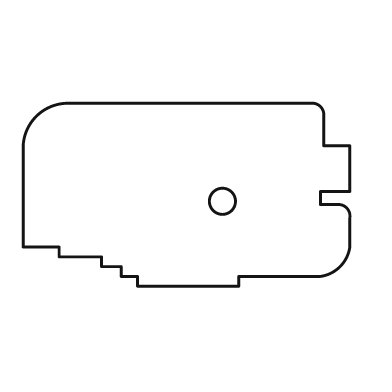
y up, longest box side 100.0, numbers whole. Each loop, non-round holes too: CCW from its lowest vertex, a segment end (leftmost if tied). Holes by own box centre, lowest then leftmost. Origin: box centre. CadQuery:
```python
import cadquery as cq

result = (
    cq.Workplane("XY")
    .moveTo(-15.0, -28.0)
    .lineTo(16.0, -28.0)
    .lineTo(16.0, -25.0)
    .lineTo(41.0, -25.0)
    .threePointArc((47.0, -22.0), (50.0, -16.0))
    .lineTo(50.0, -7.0)
    .threePointArc((49.0, -4.0), (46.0, -3.0))
    .lineTo(41.0, -3.0)
    .lineTo(41.0, 1.0)
    .lineTo(50.0, 1.0)
    .lineTo(50.0, 15.0)
    .lineTo(42.0, 15.0)
    .lineTo(42.0, 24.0)
    .threePointArc((41.0, 27.0), (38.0, 28.0))
    .lineTo(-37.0, 28.0)
    .threePointArc((-46.0, 24.0), (-50.0, 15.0))
    .lineTo(-50.0, -16.0)
    .lineTo(-39.0, -16.0)
    .lineTo(-39.0, -19.0)
    .lineTo(-26.0, -19.0)
    .lineTo(-26.0, -22.0)
    .lineTo(-20.0, -22.0)
    .lineTo(-20.0, -25.0)
    .lineTo(-15.0, -25.0)
    .close()
    .moveTo(11.0, -2.0)
    .circle(4.0)
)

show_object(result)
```